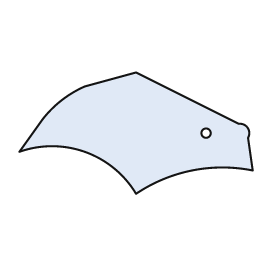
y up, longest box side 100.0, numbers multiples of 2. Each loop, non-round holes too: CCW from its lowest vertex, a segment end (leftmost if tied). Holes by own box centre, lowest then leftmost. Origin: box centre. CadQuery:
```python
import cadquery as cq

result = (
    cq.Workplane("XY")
    .moveTo(0.0, -26.0)
    .threePointArc((24.0, -16.0), (50.0, -16.0))
    .lineTo(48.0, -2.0)
    .threePointArc((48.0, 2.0), (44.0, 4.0))
    .lineTo(0.0, 26.0)
    .lineTo(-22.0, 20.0)
    .threePointArc((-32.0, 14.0), (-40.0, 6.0))
    .lineTo(-50.0, -8.0)
    .threePointArc((-22.0, -8.0), (0.0, -26.0))
    .close()
    .moveTo(30.0, 0.0)
    .circle(2.0)
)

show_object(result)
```